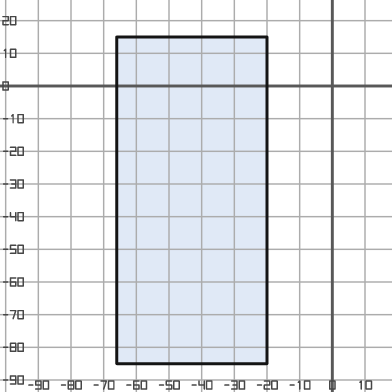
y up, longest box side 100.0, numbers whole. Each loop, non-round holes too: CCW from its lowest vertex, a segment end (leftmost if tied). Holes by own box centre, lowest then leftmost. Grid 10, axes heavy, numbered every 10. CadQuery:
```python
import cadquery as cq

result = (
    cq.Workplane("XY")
    .moveTo(-66.0, -85.0)
    .lineTo(-20.0, -85.0)
    .lineTo(-20.0, 15.0)
    .lineTo(-66.0, 15.0)
    .close()
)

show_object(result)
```